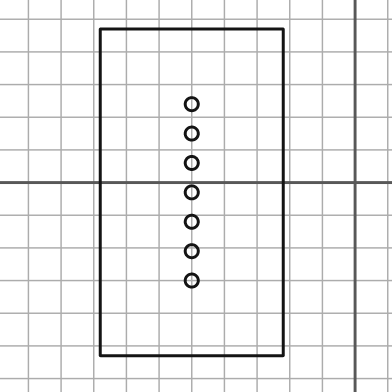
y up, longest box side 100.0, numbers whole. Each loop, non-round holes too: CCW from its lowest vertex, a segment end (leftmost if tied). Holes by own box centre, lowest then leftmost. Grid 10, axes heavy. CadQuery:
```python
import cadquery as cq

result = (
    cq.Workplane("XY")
    .moveTo(-78.0, -53.0)
    .lineTo(-22.0, -53.0)
    .lineTo(-22.0, 47.0)
    .lineTo(-78.0, 47.0)
    .close()
    .moveTo(-50.0, -30.0)
    .circle(2.0)
    .moveTo(-50.0, -21.0)
    .circle(2.0)
    .moveTo(-50.0, -12.0)
    .circle(2.0)
    .moveTo(-50.0, -3.0)
    .circle(2.0)
    .moveTo(-50.0, 6.0)
    .circle(2.0)
    .moveTo(-50.0, 15.0)
    .circle(2.0)
    .moveTo(-50.0, 24.0)
    .circle(2.0)
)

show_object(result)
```